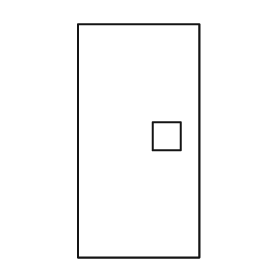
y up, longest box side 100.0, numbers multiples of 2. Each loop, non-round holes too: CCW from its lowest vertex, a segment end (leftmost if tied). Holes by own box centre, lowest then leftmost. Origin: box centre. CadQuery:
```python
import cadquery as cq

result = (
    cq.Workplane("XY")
    .moveTo(-26.0, -50.0)
    .lineTo(26.0, -50.0)
    .lineTo(26.0, 50.0)
    .lineTo(-26.0, 50.0)
    .close()
    .moveTo(6.0, -4.0)
    .lineTo(18.0, -4.0)
    .lineTo(18.0, 8.0)
    .lineTo(6.0, 8.0)
    .close()
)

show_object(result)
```